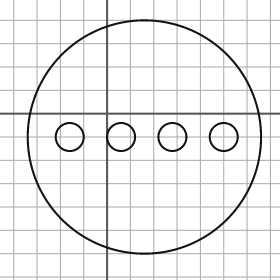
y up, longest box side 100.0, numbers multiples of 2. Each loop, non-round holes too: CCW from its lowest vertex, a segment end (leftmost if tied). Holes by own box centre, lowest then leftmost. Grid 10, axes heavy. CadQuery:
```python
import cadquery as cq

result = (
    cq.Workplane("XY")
    .moveTo(16.0, -10.0)
    .circle(50.0)
    .moveTo(-16.0, -10.0)
    .circle(6.0)
    .moveTo(6.0, -10.0)
    .circle(6.0)
    .moveTo(28.0, -10.0)
    .circle(6.0)
    .moveTo(50.0, -10.0)
    .circle(6.0)
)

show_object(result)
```